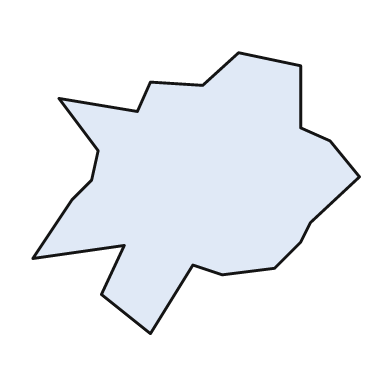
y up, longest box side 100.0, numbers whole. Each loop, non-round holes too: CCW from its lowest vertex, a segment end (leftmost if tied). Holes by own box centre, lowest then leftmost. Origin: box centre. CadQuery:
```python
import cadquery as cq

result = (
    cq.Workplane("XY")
    .moveTo(-14.0, -43.0)
    .lineTo(-1.0, -22.0)
    .lineTo(8.0, -25.0)
    .lineTo(24.0, -23.0)
    .lineTo(32.0, -15.0)
    .lineTo(35.0, -9.0)
    .lineTo(50.0, 5.0)
    .lineTo(41.0, 16.0)
    .lineTo(32.0, 20.0)
    .lineTo(32.0, 39.0)
    .lineTo(13.0, 43.0)
    .lineTo(2.0, 33.0)
    .lineTo(-14.0, 34.0)
    .lineTo(-18.0, 25.0)
    .lineTo(-42.0, 29.0)
    .lineTo(-30.0, 13.0)
    .lineTo(-32.0, 4.0)
    .lineTo(-38.0, -2.0)
    .lineTo(-50.0, -20.0)
    .lineTo(-22.0, -16.0)
    .lineTo(-29.0, -31.0)
    .close()
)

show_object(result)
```